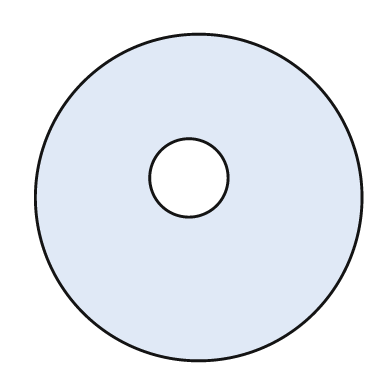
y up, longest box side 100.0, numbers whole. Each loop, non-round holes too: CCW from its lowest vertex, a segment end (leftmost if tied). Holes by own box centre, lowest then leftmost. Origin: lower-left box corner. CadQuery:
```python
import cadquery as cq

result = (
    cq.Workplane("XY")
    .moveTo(50.0, 50.0)
    .circle(50.0)
    .moveTo(47.0, 56.0)
    .circle(12.0)
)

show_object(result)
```